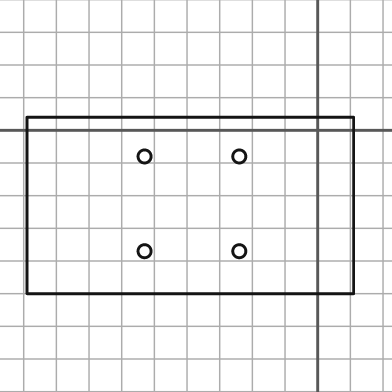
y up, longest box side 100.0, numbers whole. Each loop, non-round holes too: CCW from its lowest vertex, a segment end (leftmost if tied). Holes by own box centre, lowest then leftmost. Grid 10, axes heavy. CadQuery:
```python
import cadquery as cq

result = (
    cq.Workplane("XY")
    .moveTo(-89.0, -50.0)
    .lineTo(11.0, -50.0)
    .lineTo(11.0, 4.0)
    .lineTo(-89.0, 4.0)
    .close()
    .moveTo(-53.0, -37.0)
    .circle(2.0)
    .moveTo(-24.0, -37.0)
    .circle(2.0)
    .moveTo(-53.0, -8.0)
    .circle(2.0)
    .moveTo(-24.0, -8.0)
    .circle(2.0)
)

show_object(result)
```